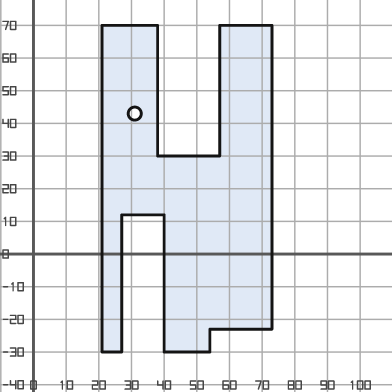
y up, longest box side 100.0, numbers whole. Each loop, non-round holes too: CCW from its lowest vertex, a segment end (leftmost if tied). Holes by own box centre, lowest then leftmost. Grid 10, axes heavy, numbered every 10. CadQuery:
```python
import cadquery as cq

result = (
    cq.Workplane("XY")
    .moveTo(21.0, -30.0)
    .lineTo(27.0, -30.0)
    .lineTo(27.0, 12.0)
    .lineTo(40.0, 12.0)
    .lineTo(40.0, -30.0)
    .lineTo(54.0, -30.0)
    .lineTo(54.0, -23.0)
    .lineTo(73.0, -23.0)
    .lineTo(73.0, 70.0)
    .lineTo(57.0, 70.0)
    .lineTo(57.0, 30.0)
    .lineTo(38.0, 30.0)
    .lineTo(38.0, 70.0)
    .lineTo(21.0, 70.0)
    .close()
    .moveTo(31.0, 43.0)
    .circle(2.0)
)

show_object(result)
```